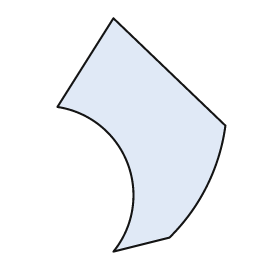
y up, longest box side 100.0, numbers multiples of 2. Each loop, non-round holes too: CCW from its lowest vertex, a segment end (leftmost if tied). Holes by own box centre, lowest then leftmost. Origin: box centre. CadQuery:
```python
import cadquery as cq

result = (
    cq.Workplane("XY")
    .moveTo(-12.0, -50.0)
    .lineTo(12.0, -44.0)
    .threePointArc((28.0, -22.0), (36.0, 4.0))
    .lineTo(-12.0, 50.0)
    .lineTo(-36.0, 12.0)
    .threePointArc((-6.0, -12.0), (-12.0, -50.0))
    .close()
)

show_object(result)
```